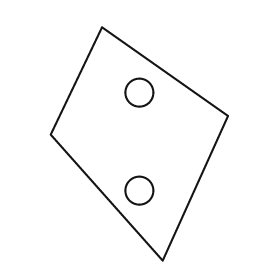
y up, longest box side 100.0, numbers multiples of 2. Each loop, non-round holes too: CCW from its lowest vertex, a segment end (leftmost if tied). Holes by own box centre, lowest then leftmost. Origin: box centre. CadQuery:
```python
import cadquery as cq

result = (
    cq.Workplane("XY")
    .moveTo(10.0, -50.0)
    .lineTo(38.0, 12.0)
    .lineTo(-16.0, 50.0)
    .lineTo(-38.0, 4.0)
    .close()
    .moveTo(0.0, -20.0)
    .circle(6.0)
    .moveTo(0.0, 22.0)
    .circle(6.0)
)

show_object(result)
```